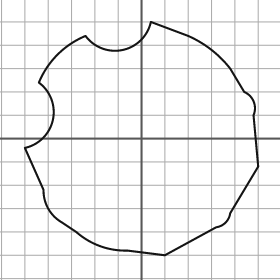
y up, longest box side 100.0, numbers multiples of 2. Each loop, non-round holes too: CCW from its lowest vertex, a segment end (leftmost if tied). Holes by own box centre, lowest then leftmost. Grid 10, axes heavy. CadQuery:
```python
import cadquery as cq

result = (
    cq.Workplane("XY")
    .moveTo(10.0, -50.0)
    .lineTo(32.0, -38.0)
    .threePointArc((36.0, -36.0), (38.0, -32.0))
    .lineTo(50.0, -12.0)
    .lineTo(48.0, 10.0)
    .threePointArc((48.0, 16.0), (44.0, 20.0))
    .lineTo(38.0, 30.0)
    .threePointArc((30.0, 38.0), (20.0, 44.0))
    .lineTo(4.0, 50.0)
    .threePointArc((-8.0, 38.0), (-24.0, 44.0))
    .threePointArc((-36.0, 36.0), (-44.0, 24.0))
    .threePointArc((-38.0, 8.0), (-50.0, -4.0))
    .lineTo(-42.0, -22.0)
    .threePointArc((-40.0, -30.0), (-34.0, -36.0))
    .lineTo(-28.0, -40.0)
    .threePointArc((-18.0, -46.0), (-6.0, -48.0))
    .close()
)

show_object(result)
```